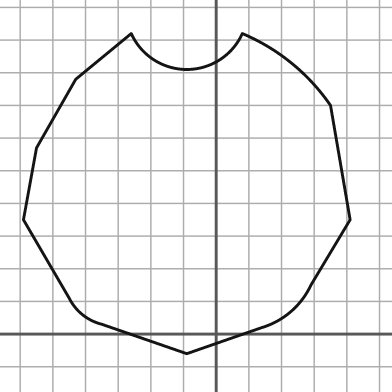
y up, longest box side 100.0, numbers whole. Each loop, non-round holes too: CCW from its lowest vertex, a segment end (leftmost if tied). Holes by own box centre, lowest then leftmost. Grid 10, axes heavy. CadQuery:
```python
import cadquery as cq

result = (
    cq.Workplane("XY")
    .moveTo(-9.0, -6.0)
    .lineTo(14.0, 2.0)
    .threePointArc((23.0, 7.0), (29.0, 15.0))
    .lineTo(41.0, 35.0)
    .lineTo(35.0, 70.0)
    .threePointArc((23.0, 83.0), (8.0, 92.0))
    .threePointArc((-9.0, 81.0), (-26.0, 92.0))
    .lineTo(-43.0, 78.0)
    .lineTo(-55.0, 57.0)
    .lineTo(-59.0, 35.0)
    .lineTo(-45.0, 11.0)
    .threePointArc((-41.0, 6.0), (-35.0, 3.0))
    .close()
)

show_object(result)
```